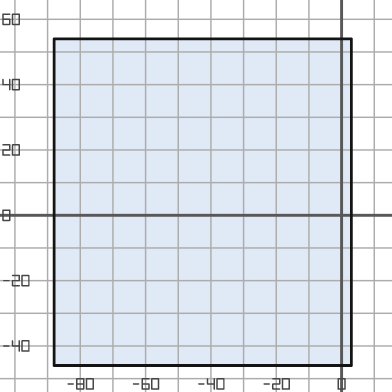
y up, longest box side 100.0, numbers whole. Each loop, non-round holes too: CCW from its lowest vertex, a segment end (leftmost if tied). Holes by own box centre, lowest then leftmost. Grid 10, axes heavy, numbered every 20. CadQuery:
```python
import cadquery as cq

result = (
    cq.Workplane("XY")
    .moveTo(-88.0, -46.0)
    .lineTo(3.0, -46.0)
    .lineTo(3.0, 54.0)
    .lineTo(-88.0, 54.0)
    .close()
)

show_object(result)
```